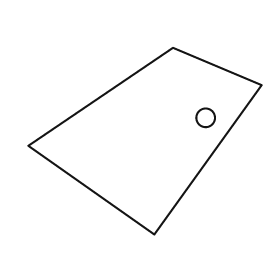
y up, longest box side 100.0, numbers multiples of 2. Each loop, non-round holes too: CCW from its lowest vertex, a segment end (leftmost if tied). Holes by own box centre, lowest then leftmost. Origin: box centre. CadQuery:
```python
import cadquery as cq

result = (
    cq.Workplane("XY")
    .moveTo(4.0, -40.0)
    .lineTo(50.0, 24.0)
    .lineTo(12.0, 40.0)
    .lineTo(-50.0, -2.0)
    .close()
    .moveTo(26.0, 10.0)
    .circle(4.0)
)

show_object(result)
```